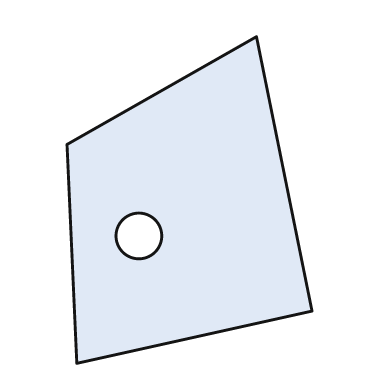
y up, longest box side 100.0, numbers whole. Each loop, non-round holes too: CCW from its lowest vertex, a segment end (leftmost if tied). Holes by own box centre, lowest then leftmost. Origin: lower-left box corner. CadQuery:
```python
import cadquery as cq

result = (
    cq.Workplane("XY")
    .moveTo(3.0, 0.0)
    .lineTo(75.0, 16.0)
    .lineTo(58.0, 100.0)
    .lineTo(0.0, 67.0)
    .close()
    .moveTo(22.0, 39.0)
    .circle(7.0)
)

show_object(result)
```